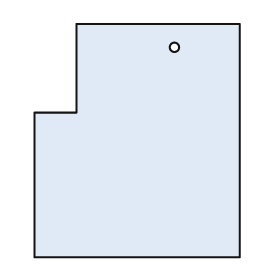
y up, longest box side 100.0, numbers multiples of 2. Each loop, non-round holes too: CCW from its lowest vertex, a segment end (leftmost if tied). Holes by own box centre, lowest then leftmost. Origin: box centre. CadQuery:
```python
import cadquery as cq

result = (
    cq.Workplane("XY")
    .moveTo(-44.0, -50.0)
    .lineTo(44.0, -50.0)
    .lineTo(44.0, 50.0)
    .lineTo(-26.0, 50.0)
    .lineTo(-26.0, 12.0)
    .lineTo(-44.0, 12.0)
    .close()
    .moveTo(16.0, 40.0)
    .circle(2.0)
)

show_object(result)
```